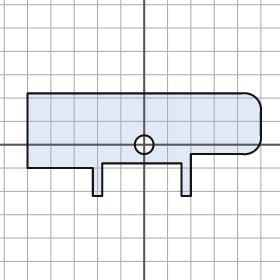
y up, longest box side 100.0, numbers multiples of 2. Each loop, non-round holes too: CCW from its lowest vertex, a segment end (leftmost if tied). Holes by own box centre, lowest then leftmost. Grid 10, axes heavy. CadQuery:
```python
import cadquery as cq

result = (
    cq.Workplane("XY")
    .moveTo(-22.0, -22.0)
    .lineTo(-18.0, -22.0)
    .lineTo(-18.0, -8.0)
    .lineTo(16.0, -8.0)
    .lineTo(16.0, -22.0)
    .lineTo(20.0, -22.0)
    .lineTo(20.0, -4.0)
    .lineTo(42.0, -4.0)
    .threePointArc((48.0, -2.0), (50.0, 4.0))
    .lineTo(50.0, 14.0)
    .threePointArc((48.0, 20.0), (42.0, 22.0))
    .lineTo(-50.0, 22.0)
    .lineTo(-50.0, -10.0)
    .lineTo(-22.0, -10.0)
    .close()
    .moveTo(0.0, 0.0)
    .circle(4.0)
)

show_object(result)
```